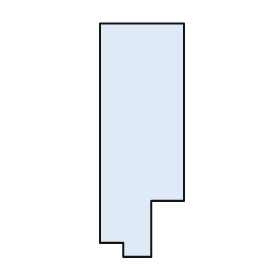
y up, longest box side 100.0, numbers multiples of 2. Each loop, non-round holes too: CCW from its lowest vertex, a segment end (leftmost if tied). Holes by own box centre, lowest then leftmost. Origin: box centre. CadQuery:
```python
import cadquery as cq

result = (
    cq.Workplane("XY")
    .moveTo(-8.0, -50.0)
    .lineTo(4.0, -50.0)
    .lineTo(4.0, -26.0)
    .lineTo(18.0, -26.0)
    .lineTo(18.0, 50.0)
    .lineTo(-18.0, 50.0)
    .lineTo(-18.0, -44.0)
    .lineTo(-8.0, -44.0)
    .close()
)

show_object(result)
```